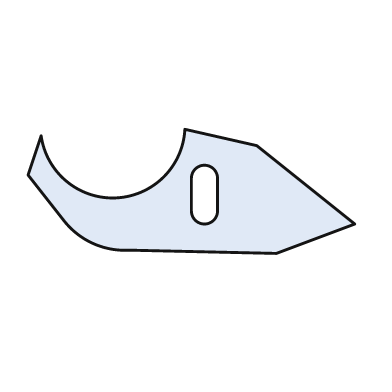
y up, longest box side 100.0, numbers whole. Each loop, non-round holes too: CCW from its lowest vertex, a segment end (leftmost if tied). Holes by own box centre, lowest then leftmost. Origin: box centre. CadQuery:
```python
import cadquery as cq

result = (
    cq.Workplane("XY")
    .moveTo(26.0, -19.0)
    .lineTo(50.0, -10.0)
    .lineTo(20.0, 14.0)
    .lineTo(-2.0, 19.0)
    .threePointArc((-23.0, -2.0), (-46.0, 17.0))
    .lineTo(-50.0, 5.0)
    .lineTo(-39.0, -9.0)
    .threePointArc((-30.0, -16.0), (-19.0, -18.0))
    .close()
    .moveTo(0.0, -6.0)
    .threePointArc((4.0, -10.0), (8.0, -6.0))
    .lineTo(8.0, 4.0)
    .threePointArc((4.0, 8.0), (0.0, 4.0))
    .close()
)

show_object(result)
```